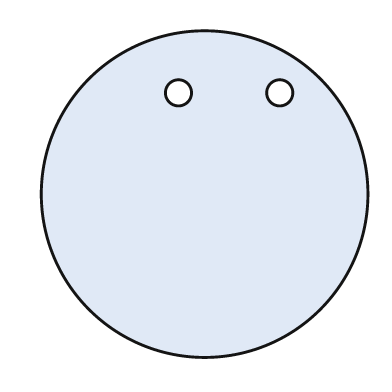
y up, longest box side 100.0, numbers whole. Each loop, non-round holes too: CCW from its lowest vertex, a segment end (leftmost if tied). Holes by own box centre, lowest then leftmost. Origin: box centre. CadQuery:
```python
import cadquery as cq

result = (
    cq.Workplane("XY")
    .moveTo(0.0, 0.0)
    .circle(50.0)
    .moveTo(-8.0, 31.0)
    .circle(4.0)
    .moveTo(23.0, 31.0)
    .circle(4.0)
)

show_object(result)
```